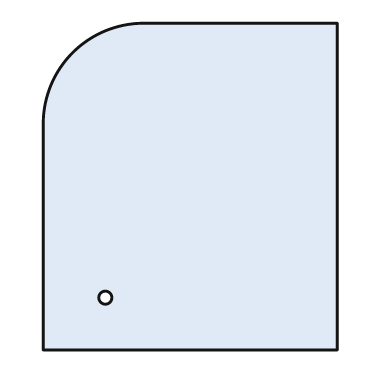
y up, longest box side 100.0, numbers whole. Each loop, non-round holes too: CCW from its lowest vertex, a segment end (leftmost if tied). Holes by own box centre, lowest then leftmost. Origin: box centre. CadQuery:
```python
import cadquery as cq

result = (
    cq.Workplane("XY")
    .moveTo(-45.0, -50.0)
    .lineTo(45.0, -50.0)
    .lineTo(45.0, 50.0)
    .lineTo(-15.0, 50.0)
    .threePointArc((-36.0, 41.0), (-45.0, 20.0))
    .close()
    .moveTo(-26.0, -34.0)
    .circle(2.0)
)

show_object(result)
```